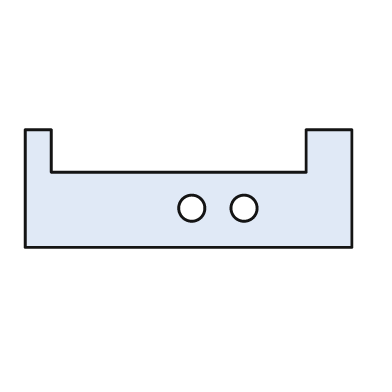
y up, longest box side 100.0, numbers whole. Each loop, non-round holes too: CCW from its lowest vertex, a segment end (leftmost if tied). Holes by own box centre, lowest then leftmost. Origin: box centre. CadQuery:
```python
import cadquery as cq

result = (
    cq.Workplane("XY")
    .moveTo(-50.0, -18.0)
    .lineTo(50.0, -18.0)
    .lineTo(50.0, 18.0)
    .lineTo(36.0, 18.0)
    .lineTo(36.0, 5.0)
    .lineTo(-42.0, 5.0)
    .lineTo(-42.0, 18.0)
    .lineTo(-50.0, 18.0)
    .close()
    .moveTo(1.0, -6.0)
    .circle(4.0)
    .moveTo(17.0, -6.0)
    .circle(4.0)
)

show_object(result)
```